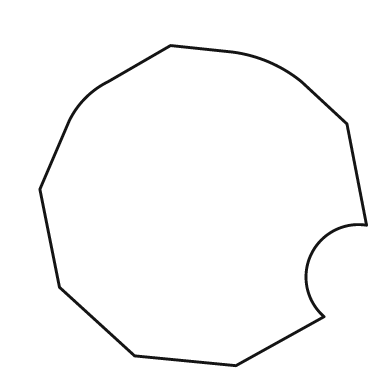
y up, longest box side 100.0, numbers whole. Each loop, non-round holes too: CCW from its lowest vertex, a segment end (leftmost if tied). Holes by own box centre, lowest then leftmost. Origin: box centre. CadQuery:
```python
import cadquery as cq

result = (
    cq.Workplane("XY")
    .moveTo(10.0, -49.0)
    .lineTo(37.0, -34.0)
    .threePointArc((33.0, -15.0), (50.0, -6.0))
    .lineTo(44.0, 25.0)
    .lineTo(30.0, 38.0)
    .threePointArc((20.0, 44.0), (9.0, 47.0))
    .lineTo(-10.0, 49.0)
    .lineTo(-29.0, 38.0)
    .threePointArc((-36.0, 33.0), (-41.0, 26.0))
    .lineTo(-50.0, 5.0)
    .lineTo(-44.0, -25.0)
    .lineTo(-21.0, -46.0)
    .close()
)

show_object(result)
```